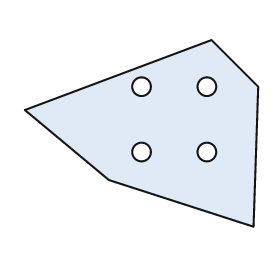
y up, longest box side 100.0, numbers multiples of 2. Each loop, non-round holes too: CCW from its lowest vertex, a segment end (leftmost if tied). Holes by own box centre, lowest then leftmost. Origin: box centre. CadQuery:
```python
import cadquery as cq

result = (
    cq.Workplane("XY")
    .moveTo(48.0, -40.0)
    .lineTo(50.0, 20.0)
    .lineTo(30.0, 40.0)
    .lineTo(-50.0, 10.0)
    .lineTo(-14.0, -20.0)
    .close()
    .moveTo(0.0, -8.0)
    .circle(4.0)
    .moveTo(28.0, -8.0)
    .circle(4.0)
    .moveTo(0.0, 20.0)
    .circle(4.0)
    .moveTo(28.0, 20.0)
    .circle(4.0)
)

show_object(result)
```